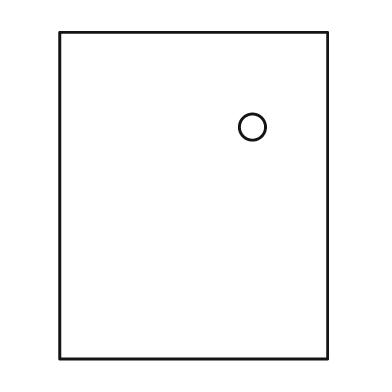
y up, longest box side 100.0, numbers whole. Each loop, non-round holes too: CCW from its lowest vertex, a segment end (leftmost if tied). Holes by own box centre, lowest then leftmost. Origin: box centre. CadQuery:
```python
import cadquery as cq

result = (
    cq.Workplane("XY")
    .moveTo(-41.0, -50.0)
    .lineTo(41.0, -50.0)
    .lineTo(41.0, 50.0)
    .lineTo(-41.0, 50.0)
    .close()
    .moveTo(18.0, 21.0)
    .circle(4.0)
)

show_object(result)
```